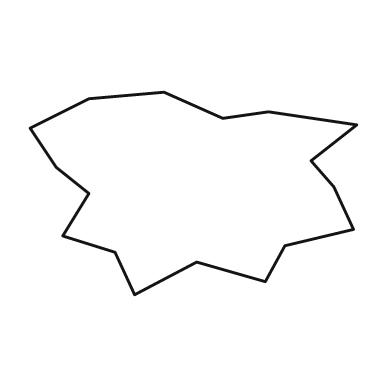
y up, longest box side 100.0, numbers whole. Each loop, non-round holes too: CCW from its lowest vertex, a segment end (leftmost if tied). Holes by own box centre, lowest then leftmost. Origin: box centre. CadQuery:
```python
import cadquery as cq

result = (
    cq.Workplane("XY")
    .moveTo(-18.0, -31.0)
    .lineTo(1.0, -21.0)
    .lineTo(22.0, -27.0)
    .lineTo(28.0, -16.0)
    .lineTo(49.0, -11.0)
    .lineTo(43.0, 2.0)
    .lineTo(36.0, 10.0)
    .lineTo(50.0, 21.0)
    .lineTo(23.0, 25.0)
    .lineTo(9.0, 23.0)
    .lineTo(-9.0, 31.0)
    .lineTo(-32.0, 29.0)
    .lineTo(-50.0, 20.0)
    .lineTo(-42.0, 8.0)
    .lineTo(-32.0, 0.0)
    .lineTo(-40.0, -13.0)
    .lineTo(-24.0, -18.0)
    .close()
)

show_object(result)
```